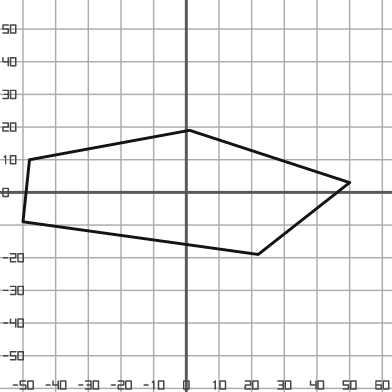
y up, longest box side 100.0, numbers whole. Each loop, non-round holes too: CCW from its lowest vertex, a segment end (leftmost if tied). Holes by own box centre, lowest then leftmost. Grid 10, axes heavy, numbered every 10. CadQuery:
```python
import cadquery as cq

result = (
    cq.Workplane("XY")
    .moveTo(22.0, -19.0)
    .lineTo(50.0, 3.0)
    .lineTo(1.0, 19.0)
    .lineTo(-48.0, 10.0)
    .lineTo(-50.0, -9.0)
    .close()
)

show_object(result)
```